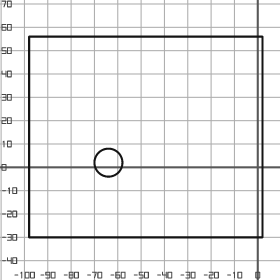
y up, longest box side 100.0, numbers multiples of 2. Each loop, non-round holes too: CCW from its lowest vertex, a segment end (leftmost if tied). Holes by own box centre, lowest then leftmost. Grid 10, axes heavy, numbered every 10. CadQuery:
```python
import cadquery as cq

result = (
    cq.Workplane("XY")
    .moveTo(-98.0, -30.0)
    .lineTo(2.0, -30.0)
    .lineTo(2.0, 56.0)
    .lineTo(-98.0, 56.0)
    .close()
    .moveTo(-64.0, 2.0)
    .circle(6.0)
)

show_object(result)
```